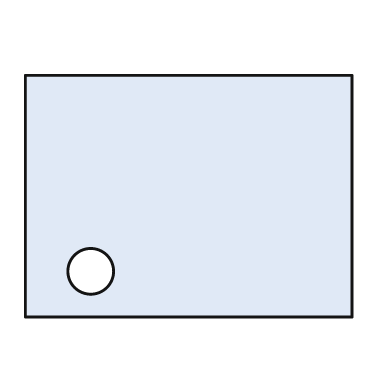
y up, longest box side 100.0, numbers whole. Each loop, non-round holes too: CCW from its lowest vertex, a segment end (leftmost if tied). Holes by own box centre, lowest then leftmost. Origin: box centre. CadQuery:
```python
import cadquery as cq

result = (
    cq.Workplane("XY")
    .moveTo(-50.0, -37.0)
    .lineTo(50.0, -37.0)
    .lineTo(50.0, 37.0)
    .lineTo(-50.0, 37.0)
    .close()
    .moveTo(-30.0, -23.0)
    .circle(7.0)
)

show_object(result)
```